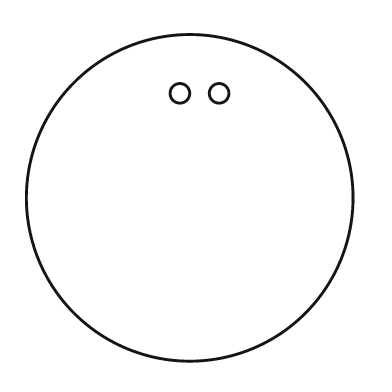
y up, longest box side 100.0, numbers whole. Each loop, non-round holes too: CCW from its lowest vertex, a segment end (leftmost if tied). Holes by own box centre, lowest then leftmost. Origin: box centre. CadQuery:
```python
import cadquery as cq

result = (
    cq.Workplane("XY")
    .moveTo(0.0, 0.0)
    .circle(50.0)
    .moveTo(-3.0, 32.0)
    .circle(3.0)
    .moveTo(9.0, 32.0)
    .circle(3.0)
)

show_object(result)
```